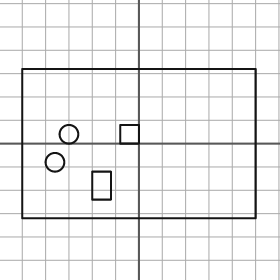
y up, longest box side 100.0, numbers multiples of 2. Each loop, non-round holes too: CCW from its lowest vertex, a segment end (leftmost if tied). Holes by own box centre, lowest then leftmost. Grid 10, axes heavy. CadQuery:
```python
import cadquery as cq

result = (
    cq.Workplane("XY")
    .moveTo(-50.0, -32.0)
    .lineTo(50.0, -32.0)
    .lineTo(50.0, 32.0)
    .lineTo(-50.0, 32.0)
    .close()
    .moveTo(-20.0, -24.0)
    .lineTo(-12.0, -24.0)
    .lineTo(-12.0, -12.0)
    .lineTo(-20.0, -12.0)
    .close()
    .moveTo(-36.0, -8.0)
    .circle(4.0)
    .moveTo(-30.0, 4.0)
    .circle(4.0)
    .moveTo(-8.0, 0.0)
    .lineTo(0.0, 0.0)
    .lineTo(0.0, 8.0)
    .lineTo(-8.0, 8.0)
    .close()
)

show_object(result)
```